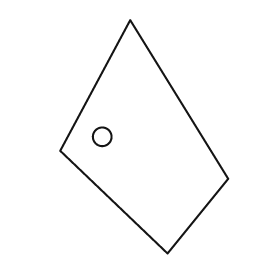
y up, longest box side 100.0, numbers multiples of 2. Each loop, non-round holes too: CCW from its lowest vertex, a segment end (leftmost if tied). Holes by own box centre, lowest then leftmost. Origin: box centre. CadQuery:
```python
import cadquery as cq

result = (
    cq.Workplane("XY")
    .moveTo(10.0, -50.0)
    .lineTo(36.0, -18.0)
    .lineTo(-6.0, 50.0)
    .lineTo(-36.0, -6.0)
    .close()
    .moveTo(-18.0, 0.0)
    .circle(4.0)
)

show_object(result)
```